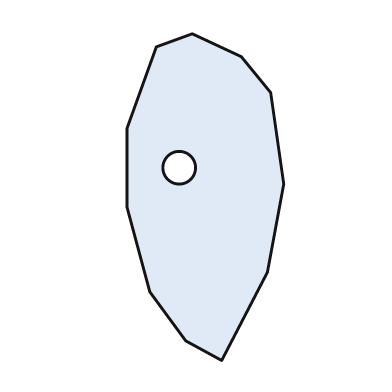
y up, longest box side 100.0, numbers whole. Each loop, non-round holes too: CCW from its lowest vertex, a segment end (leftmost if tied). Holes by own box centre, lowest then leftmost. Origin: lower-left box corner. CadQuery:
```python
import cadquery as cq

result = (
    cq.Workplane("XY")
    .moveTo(29.0, 0.0)
    .lineTo(43.0, 27.0)
    .lineTo(48.0, 54.0)
    .lineTo(44.0, 82.0)
    .lineTo(35.0, 93.0)
    .lineTo(20.0, 100.0)
    .lineTo(9.0, 96.0)
    .lineTo(0.0, 71.0)
    .lineTo(0.0, 47.0)
    .lineTo(7.0, 21.0)
    .lineTo(18.0, 6.0)
    .close()
    .moveTo(16.0, 59.0)
    .circle(5.0)
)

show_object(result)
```